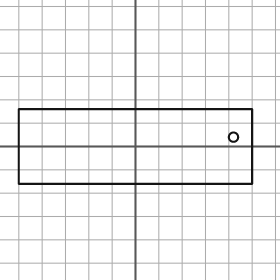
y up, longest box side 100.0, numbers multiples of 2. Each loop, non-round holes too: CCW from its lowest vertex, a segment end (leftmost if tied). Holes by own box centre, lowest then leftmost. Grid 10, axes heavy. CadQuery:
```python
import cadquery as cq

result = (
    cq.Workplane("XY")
    .moveTo(-50.0, -16.0)
    .lineTo(50.0, -16.0)
    .lineTo(50.0, 16.0)
    .lineTo(-50.0, 16.0)
    .close()
    .moveTo(42.0, 4.0)
    .circle(2.0)
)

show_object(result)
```